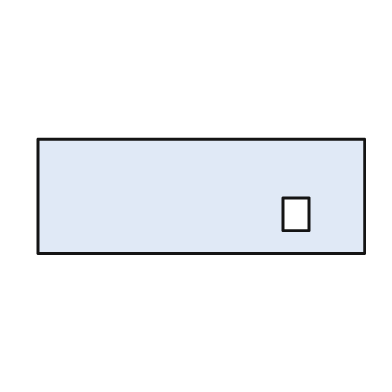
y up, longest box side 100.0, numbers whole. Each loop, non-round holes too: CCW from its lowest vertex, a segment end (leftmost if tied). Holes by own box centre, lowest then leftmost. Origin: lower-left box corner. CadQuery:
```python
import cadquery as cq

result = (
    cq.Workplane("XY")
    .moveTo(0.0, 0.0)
    .lineTo(100.0, 0.0)
    .lineTo(100.0, 35.0)
    .lineTo(0.0, 35.0)
    .close()
    .moveTo(75.0, 7.0)
    .lineTo(83.0, 7.0)
    .lineTo(83.0, 17.0)
    .lineTo(75.0, 17.0)
    .close()
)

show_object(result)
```